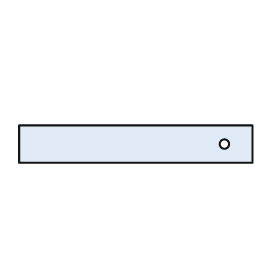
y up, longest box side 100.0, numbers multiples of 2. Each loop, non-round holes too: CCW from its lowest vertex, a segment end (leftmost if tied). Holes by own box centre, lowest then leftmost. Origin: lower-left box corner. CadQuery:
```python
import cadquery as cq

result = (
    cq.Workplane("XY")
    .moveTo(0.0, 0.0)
    .lineTo(100.0, 0.0)
    .lineTo(100.0, 16.0)
    .lineTo(0.0, 16.0)
    .close()
    .moveTo(88.0, 8.0)
    .circle(2.0)
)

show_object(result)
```